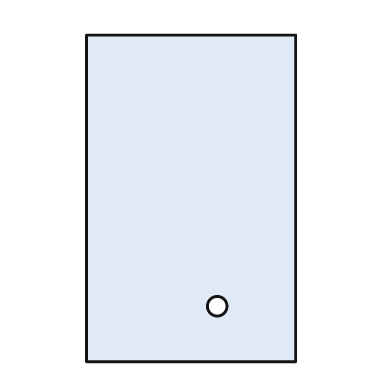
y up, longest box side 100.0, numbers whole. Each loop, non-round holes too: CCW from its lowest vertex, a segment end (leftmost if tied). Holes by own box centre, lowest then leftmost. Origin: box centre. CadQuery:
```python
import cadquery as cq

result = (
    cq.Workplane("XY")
    .moveTo(-32.0, -50.0)
    .lineTo(32.0, -50.0)
    .lineTo(32.0, 50.0)
    .lineTo(-32.0, 50.0)
    .close()
    .moveTo(8.0, -33.0)
    .circle(3.0)
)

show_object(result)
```